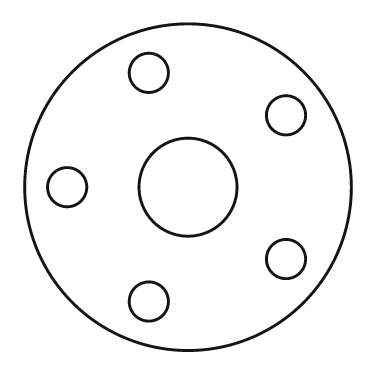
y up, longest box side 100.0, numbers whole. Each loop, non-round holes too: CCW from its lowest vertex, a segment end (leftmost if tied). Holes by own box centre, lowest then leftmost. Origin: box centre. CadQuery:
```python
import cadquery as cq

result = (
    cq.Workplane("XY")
    .moveTo(0.0, 0.0)
    .circle(50.0)
    .moveTo(-12.0, -35.0)
    .circle(6.0)
    .moveTo(30.0, -22.0)
    .circle(6.0)
    .moveTo(-37.0, 0.0)
    .circle(6.0)
    .moveTo(0.0, 0.0)
    .circle(15.0)
    .moveTo(30.0, 22.0)
    .circle(6.0)
    .moveTo(-12.0, 35.0)
    .circle(6.0)
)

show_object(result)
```